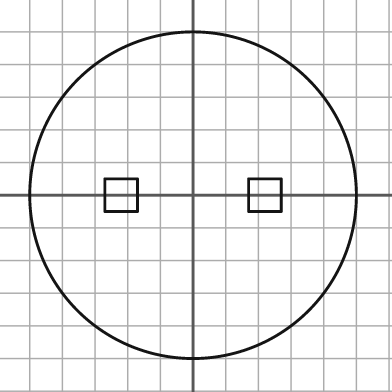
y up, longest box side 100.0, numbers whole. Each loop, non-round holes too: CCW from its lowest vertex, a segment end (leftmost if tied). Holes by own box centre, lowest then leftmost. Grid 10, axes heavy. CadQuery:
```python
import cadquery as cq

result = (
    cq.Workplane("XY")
    .moveTo(0.0, 0.0)
    .circle(50.0)
    .moveTo(-27.0, -5.0)
    .lineTo(-17.0, -5.0)
    .lineTo(-17.0, 5.0)
    .lineTo(-27.0, 5.0)
    .close()
    .moveTo(17.0, -5.0)
    .lineTo(27.0, -5.0)
    .lineTo(27.0, 5.0)
    .lineTo(17.0, 5.0)
    .close()
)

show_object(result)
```